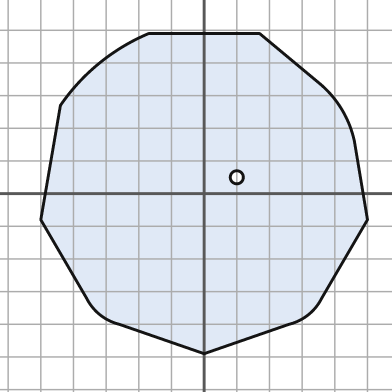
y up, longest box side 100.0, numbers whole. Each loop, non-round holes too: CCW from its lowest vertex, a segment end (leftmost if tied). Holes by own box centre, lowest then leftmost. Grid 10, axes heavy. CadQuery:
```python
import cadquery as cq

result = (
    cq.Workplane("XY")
    .moveTo(0.0, -49.0)
    .lineTo(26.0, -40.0)
    .threePointArc((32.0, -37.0), (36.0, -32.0))
    .lineTo(50.0, -8.0)
    .lineTo(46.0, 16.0)
    .threePointArc((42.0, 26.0), (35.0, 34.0))
    .lineTo(17.0, 49.0)
    .lineTo(-17.0, 49.0)
    .threePointArc((-32.0, 40.0), (-44.0, 27.0))
    .lineTo(-50.0, -8.0)
    .lineTo(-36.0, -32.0)
    .threePointArc((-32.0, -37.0), (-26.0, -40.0))
    .close()
    .moveTo(10.0, 5.0)
    .circle(2.0)
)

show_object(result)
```